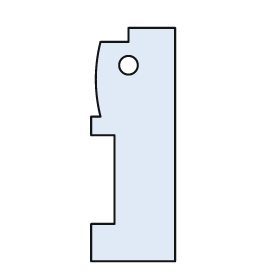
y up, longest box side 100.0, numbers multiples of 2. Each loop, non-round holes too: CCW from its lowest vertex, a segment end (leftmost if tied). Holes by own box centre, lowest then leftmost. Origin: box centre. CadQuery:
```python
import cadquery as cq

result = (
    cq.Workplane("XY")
    .moveTo(-18.0, -50.0)
    .lineTo(18.0, -50.0)
    .lineTo(18.0, 50.0)
    .lineTo(-2.0, 50.0)
    .lineTo(-2.0, 44.0)
    .lineTo(-14.0, 44.0)
    .threePointArc((-16.0, 28.0), (-14.0, 12.0))
    .lineTo(-18.0, 12.0)
    .lineTo(-18.0, 4.0)
    .lineTo(-8.0, 4.0)
    .lineTo(-8.0, -34.0)
    .lineTo(-18.0, -34.0)
    .close()
    .moveTo(-2.0, 34.0)
    .circle(4.0)
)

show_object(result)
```